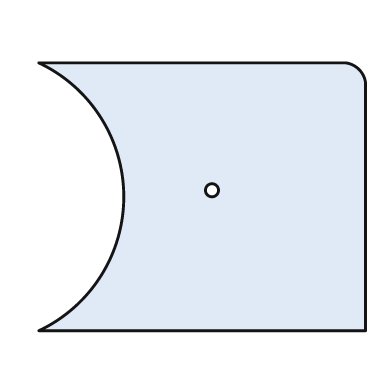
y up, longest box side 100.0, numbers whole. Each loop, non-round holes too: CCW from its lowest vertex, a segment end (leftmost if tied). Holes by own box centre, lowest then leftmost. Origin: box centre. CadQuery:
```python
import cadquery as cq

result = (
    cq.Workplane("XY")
    .moveTo(-50.0, -41.0)
    .lineTo(50.0, -41.0)
    .lineTo(50.0, 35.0)
    .threePointArc((48.0, 39.0), (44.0, 41.0))
    .lineTo(-50.0, 41.0)
    .threePointArc((-24.0, 0.0), (-50.0, -41.0))
    .close()
    .moveTo(3.0, 2.0)
    .circle(2.0)
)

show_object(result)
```